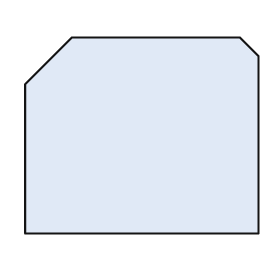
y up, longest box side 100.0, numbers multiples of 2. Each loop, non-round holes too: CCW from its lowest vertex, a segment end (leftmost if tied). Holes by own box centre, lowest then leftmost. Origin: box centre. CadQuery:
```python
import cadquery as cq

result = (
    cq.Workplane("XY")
    .moveTo(-50.0, -42.0)
    .lineTo(50.0, -42.0)
    .lineTo(50.0, 34.0)
    .lineTo(42.0, 42.0)
    .lineTo(-30.0, 42.0)
    .lineTo(-50.0, 22.0)
    .close()
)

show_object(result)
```